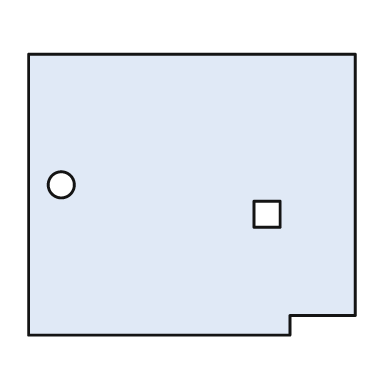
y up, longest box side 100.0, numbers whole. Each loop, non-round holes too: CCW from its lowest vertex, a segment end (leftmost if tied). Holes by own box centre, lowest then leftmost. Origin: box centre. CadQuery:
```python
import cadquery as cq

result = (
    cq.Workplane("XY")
    .moveTo(-50.0, -43.0)
    .lineTo(30.0, -43.0)
    .lineTo(30.0, -37.0)
    .lineTo(50.0, -37.0)
    .lineTo(50.0, 43.0)
    .lineTo(-50.0, 43.0)
    .close()
    .moveTo(19.0, -10.0)
    .lineTo(27.0, -10.0)
    .lineTo(27.0, -2.0)
    .lineTo(19.0, -2.0)
    .close()
    .moveTo(-40.0, 3.0)
    .circle(4.0)
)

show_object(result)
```